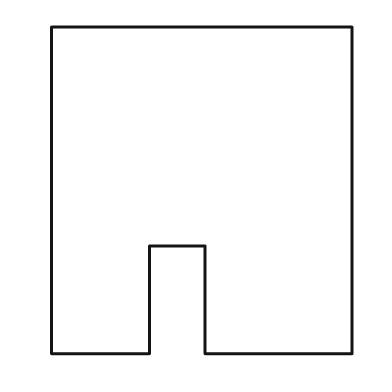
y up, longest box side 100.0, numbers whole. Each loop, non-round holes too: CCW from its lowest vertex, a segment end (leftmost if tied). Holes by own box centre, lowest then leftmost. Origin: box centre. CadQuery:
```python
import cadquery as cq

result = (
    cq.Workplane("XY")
    .moveTo(-46.0, -50.0)
    .lineTo(-16.0, -50.0)
    .lineTo(-16.0, -17.0)
    .lineTo(1.0, -17.0)
    .lineTo(1.0, -50.0)
    .lineTo(46.0, -50.0)
    .lineTo(46.0, 50.0)
    .lineTo(-46.0, 50.0)
    .close()
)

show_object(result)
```